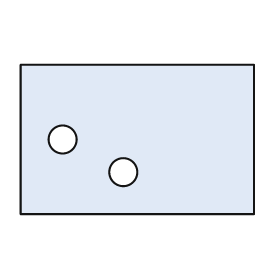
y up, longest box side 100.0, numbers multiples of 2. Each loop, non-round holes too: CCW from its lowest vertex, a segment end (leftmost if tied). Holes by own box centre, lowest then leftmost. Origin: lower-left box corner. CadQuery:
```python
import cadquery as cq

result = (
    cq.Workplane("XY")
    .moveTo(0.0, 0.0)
    .lineTo(100.0, 0.0)
    .lineTo(100.0, 64.0)
    .lineTo(0.0, 64.0)
    .close()
    .moveTo(44.0, 18.0)
    .circle(6.0)
    .moveTo(18.0, 32.0)
    .circle(6.0)
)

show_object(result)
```